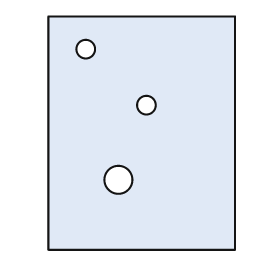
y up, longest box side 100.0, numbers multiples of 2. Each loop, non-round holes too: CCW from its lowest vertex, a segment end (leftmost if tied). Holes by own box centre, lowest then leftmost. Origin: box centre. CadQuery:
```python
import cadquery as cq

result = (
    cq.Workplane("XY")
    .moveTo(-40.0, -50.0)
    .lineTo(40.0, -50.0)
    .lineTo(40.0, 50.0)
    .lineTo(-40.0, 50.0)
    .close()
    .moveTo(-10.0, -20.0)
    .circle(6.0)
    .moveTo(2.0, 12.0)
    .circle(4.0)
    .moveTo(-24.0, 36.0)
    .circle(4.0)
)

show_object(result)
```